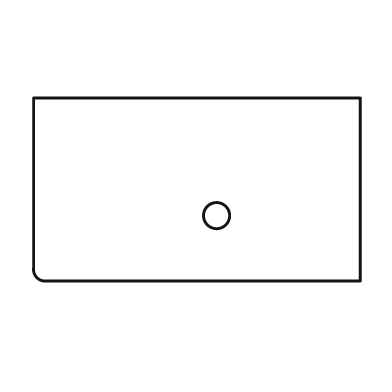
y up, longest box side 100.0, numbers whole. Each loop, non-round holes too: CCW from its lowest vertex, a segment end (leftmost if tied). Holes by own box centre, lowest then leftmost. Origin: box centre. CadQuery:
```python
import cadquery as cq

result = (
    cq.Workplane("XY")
    .moveTo(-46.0, -28.0)
    .lineTo(50.0, -28.0)
    .lineTo(50.0, 28.0)
    .lineTo(-50.0, 28.0)
    .lineTo(-50.0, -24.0)
    .threePointArc((-49.0, -27.0), (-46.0, -28.0))
    .close()
    .moveTo(6.0, -8.0)
    .circle(4.0)
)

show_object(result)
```